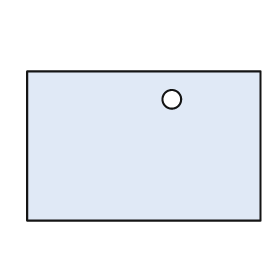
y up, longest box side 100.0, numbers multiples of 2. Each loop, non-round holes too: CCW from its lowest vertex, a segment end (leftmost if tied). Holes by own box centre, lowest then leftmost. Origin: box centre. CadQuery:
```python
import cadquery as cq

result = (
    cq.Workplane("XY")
    .moveTo(-50.0, -32.0)
    .lineTo(50.0, -32.0)
    .lineTo(50.0, 32.0)
    .lineTo(-50.0, 32.0)
    .close()
    .moveTo(12.0, 20.0)
    .circle(4.0)
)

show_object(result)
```